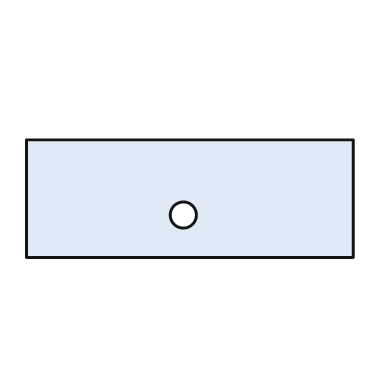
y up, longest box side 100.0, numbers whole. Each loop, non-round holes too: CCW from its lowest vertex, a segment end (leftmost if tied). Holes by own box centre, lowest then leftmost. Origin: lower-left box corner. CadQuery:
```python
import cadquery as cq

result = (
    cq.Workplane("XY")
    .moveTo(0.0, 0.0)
    .lineTo(100.0, 0.0)
    .lineTo(100.0, 36.0)
    .lineTo(0.0, 36.0)
    .close()
    .moveTo(48.0, 13.0)
    .circle(4.0)
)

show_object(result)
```